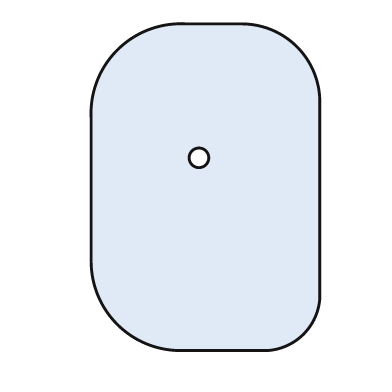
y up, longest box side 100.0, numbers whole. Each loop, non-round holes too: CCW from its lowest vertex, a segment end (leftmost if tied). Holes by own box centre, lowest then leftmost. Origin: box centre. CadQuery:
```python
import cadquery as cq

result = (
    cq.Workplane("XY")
    .moveTo(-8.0, -50.0)
    .lineTo(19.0, -50.0)
    .threePointArc((30.0, -45.0), (35.0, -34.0))
    .lineTo(35.0, 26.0)
    .threePointArc((28.0, 43.0), (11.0, 50.0))
    .lineTo(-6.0, 50.0)
    .threePointArc((-27.0, 42.0), (-35.0, 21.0))
    .lineTo(-35.0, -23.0)
    .threePointArc((-27.0, -42.0), (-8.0, -50.0))
    .close()
    .moveTo(-2.0, 9.0)
    .circle(3.0)
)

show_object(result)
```